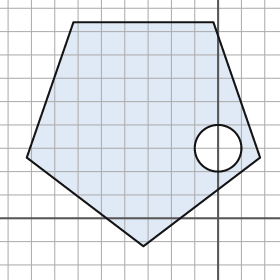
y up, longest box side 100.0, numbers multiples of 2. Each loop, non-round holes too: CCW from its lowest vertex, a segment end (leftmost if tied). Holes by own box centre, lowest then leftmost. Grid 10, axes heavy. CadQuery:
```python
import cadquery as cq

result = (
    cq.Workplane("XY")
    .moveTo(-32.0, -12.0)
    .lineTo(18.0, 26.0)
    .lineTo(-2.0, 84.0)
    .lineTo(-62.0, 84.0)
    .lineTo(-82.0, 26.0)
    .close()
    .moveTo(0.0, 30.0)
    .circle(10.0)
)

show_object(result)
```